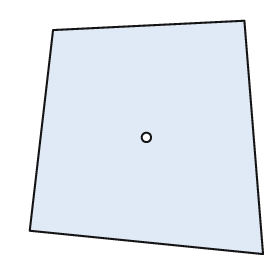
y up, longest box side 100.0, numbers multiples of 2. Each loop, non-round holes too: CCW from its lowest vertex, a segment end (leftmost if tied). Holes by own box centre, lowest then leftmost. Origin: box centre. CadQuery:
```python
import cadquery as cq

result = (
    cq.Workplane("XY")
    .moveTo(50.0, -50.0)
    .lineTo(42.0, 50.0)
    .lineTo(-40.0, 46.0)
    .lineTo(-50.0, -40.0)
    .close()
    .moveTo(0.0, 0.0)
    .circle(2.0)
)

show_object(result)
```